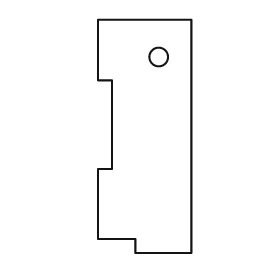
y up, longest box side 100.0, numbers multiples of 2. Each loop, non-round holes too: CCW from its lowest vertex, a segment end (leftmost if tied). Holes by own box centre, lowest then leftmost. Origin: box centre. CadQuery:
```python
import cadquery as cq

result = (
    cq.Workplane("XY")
    .moveTo(-4.0, -50.0)
    .lineTo(20.0, -50.0)
    .lineTo(20.0, 50.0)
    .lineTo(-20.0, 50.0)
    .lineTo(-20.0, 24.0)
    .lineTo(-14.0, 24.0)
    .lineTo(-14.0, -14.0)
    .lineTo(-20.0, -14.0)
    .lineTo(-20.0, -44.0)
    .lineTo(-4.0, -44.0)
    .close()
    .moveTo(6.0, 34.0)
    .circle(4.0)
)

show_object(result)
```